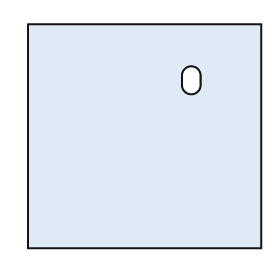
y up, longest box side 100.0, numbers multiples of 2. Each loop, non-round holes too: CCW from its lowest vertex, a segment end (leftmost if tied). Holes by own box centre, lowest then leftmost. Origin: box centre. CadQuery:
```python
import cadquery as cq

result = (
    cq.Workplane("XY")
    .moveTo(-50.0, -48.0)
    .lineTo(50.0, -48.0)
    .lineTo(50.0, 48.0)
    .lineTo(-50.0, 48.0)
    .close()
    .moveTo(16.0, 22.0)
    .threePointArc((20.0, 18.0), (24.0, 22.0))
    .lineTo(24.0, 26.0)
    .threePointArc((20.0, 30.0), (16.0, 26.0))
    .close()
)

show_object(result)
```